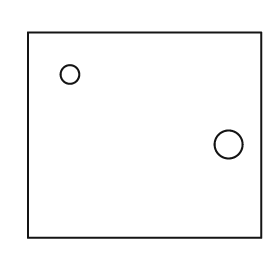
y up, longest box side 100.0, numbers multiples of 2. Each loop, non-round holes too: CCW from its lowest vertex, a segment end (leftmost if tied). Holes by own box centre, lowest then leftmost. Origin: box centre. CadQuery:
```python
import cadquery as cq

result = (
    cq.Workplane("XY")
    .moveTo(-50.0, -44.0)
    .lineTo(50.0, -44.0)
    .lineTo(50.0, 44.0)
    .lineTo(-50.0, 44.0)
    .close()
    .moveTo(36.0, -4.0)
    .circle(6.0)
    .moveTo(-32.0, 26.0)
    .circle(4.0)
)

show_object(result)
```